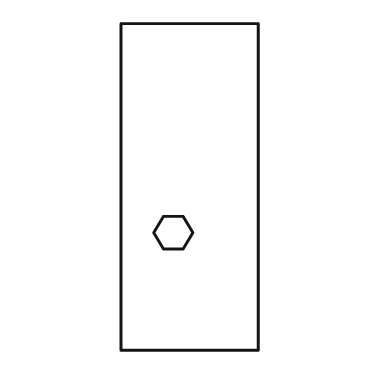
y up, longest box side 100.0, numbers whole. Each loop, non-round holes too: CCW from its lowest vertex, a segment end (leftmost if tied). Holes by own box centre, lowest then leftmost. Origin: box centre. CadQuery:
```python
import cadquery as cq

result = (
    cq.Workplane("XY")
    .moveTo(-21.0, -50.0)
    .lineTo(21.0, -50.0)
    .lineTo(21.0, 50.0)
    .lineTo(-21.0, 50.0)
    .close()
    .moveTo(-8.0, -19.0)
    .lineTo(-2.0, -19.0)
    .lineTo(1.0, -14.0)
    .lineTo(-2.0, -9.0)
    .lineTo(-8.0, -9.0)
    .lineTo(-11.0, -14.0)
    .close()
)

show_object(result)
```